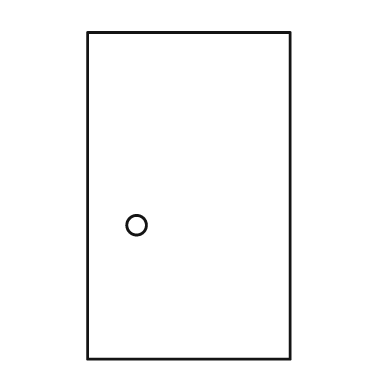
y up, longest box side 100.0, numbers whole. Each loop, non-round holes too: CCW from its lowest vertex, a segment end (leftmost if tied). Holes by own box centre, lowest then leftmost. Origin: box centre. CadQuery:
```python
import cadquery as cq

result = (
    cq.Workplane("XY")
    .moveTo(-31.0, -50.0)
    .lineTo(31.0, -50.0)
    .lineTo(31.0, 50.0)
    .lineTo(-31.0, 50.0)
    .close()
    .moveTo(-16.0, -9.0)
    .circle(3.0)
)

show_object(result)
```